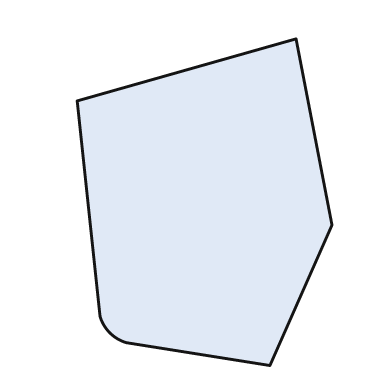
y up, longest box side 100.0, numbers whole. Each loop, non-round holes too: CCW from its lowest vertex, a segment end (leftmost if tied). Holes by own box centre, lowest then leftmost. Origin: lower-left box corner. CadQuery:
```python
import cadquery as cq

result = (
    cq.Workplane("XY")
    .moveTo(59.0, 0.0)
    .lineTo(78.0, 43.0)
    .lineTo(67.0, 100.0)
    .lineTo(0.0, 81.0)
    .lineTo(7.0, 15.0)
    .threePointArc((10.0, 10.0), (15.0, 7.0))
    .close()
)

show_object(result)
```